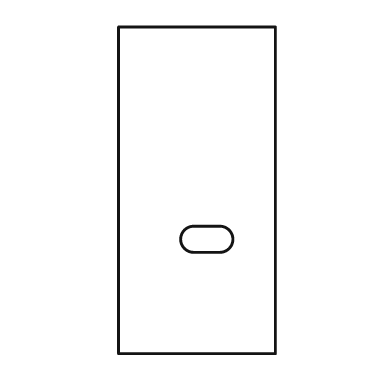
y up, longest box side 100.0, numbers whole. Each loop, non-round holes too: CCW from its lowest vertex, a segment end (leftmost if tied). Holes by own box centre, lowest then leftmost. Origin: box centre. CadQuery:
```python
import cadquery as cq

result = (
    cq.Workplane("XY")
    .moveTo(-24.0, -50.0)
    .lineTo(24.0, -50.0)
    .lineTo(24.0, 50.0)
    .lineTo(-24.0, 50.0)
    .close()
    .moveTo(-1.0, -19.0)
    .lineTo(7.0, -19.0)
    .threePointArc((11.0, -15.0), (7.0, -11.0))
    .lineTo(-1.0, -11.0)
    .threePointArc((-5.0, -15.0), (-1.0, -19.0))
    .close()
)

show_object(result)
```